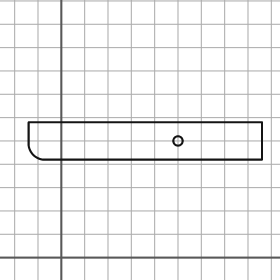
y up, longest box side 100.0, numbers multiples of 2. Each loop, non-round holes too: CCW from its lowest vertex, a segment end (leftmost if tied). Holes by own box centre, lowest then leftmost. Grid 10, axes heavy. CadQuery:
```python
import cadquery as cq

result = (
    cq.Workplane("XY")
    .moveTo(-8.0, 42.0)
    .lineTo(86.0, 42.0)
    .lineTo(86.0, 58.0)
    .lineTo(-14.0, 58.0)
    .lineTo(-14.0, 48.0)
    .threePointArc((-12.0, 44.0), (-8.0, 42.0))
    .close()
    .moveTo(50.0, 50.0)
    .circle(2.0)
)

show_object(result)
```